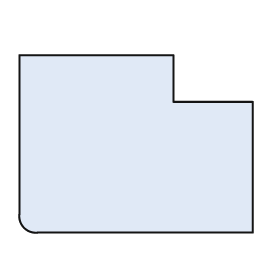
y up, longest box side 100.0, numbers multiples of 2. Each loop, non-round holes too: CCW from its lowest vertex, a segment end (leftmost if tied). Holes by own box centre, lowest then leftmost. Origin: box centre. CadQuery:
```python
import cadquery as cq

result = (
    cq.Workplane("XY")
    .moveTo(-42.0, -38.0)
    .lineTo(50.0, -38.0)
    .lineTo(50.0, 18.0)
    .lineTo(16.0, 18.0)
    .lineTo(16.0, 38.0)
    .lineTo(-50.0, 38.0)
    .lineTo(-50.0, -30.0)
    .threePointArc((-48.0, -36.0), (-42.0, -38.0))
    .close()
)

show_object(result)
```